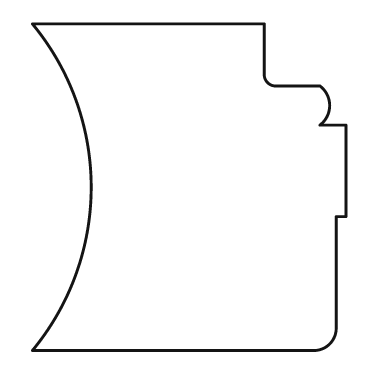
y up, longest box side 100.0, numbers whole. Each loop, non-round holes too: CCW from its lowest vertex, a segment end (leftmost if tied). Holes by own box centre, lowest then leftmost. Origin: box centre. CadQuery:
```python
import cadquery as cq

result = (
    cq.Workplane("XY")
    .moveTo(-48.0, -50.0)
    .lineTo(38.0, -50.0)
    .threePointArc((43.0, -48.0), (45.0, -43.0))
    .lineTo(45.0, -9.0)
    .lineTo(48.0, -9.0)
    .lineTo(48.0, 19.0)
    .lineTo(40.0, 19.0)
    .threePointArc((43.0, 25.0), (40.0, 31.0))
    .lineTo(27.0, 31.0)
    .threePointArc((24.0, 32.0), (23.0, 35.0))
    .lineTo(23.0, 50.0)
    .lineTo(-48.0, 50.0)
    .threePointArc((-30.0, 0.0), (-48.0, -50.0))
    .close()
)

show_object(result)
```